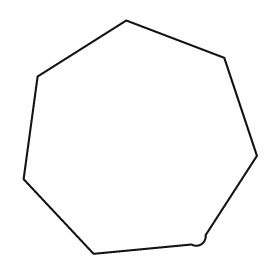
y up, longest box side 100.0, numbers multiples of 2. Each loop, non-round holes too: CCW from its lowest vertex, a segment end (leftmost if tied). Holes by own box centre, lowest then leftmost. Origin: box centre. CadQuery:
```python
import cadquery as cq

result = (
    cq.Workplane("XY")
    .moveTo(-20.0, -50.0)
    .lineTo(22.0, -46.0)
    .threePointArc((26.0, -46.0), (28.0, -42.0))
    .lineTo(50.0, -8.0)
    .lineTo(36.0, 34.0)
    .lineTo(-6.0, 50.0)
    .lineTo(-44.0, 26.0)
    .lineTo(-50.0, -18.0)
    .close()
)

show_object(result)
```